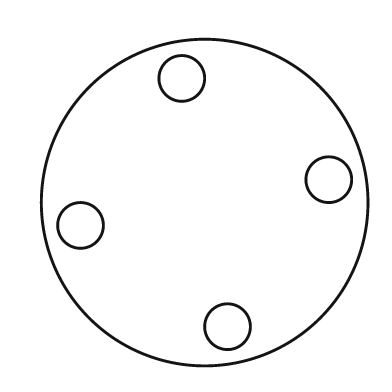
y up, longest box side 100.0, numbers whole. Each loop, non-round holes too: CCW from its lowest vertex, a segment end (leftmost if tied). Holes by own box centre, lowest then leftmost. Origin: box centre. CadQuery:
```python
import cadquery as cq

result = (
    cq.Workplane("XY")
    .moveTo(0.0, 0.0)
    .circle(50.0)
    .moveTo(7.0, -38.0)
    .circle(7.0)
    .moveTo(-38.0, -7.0)
    .circle(7.0)
    .moveTo(38.0, 7.0)
    .circle(7.0)
    .moveTo(-7.0, 38.0)
    .circle(7.0)
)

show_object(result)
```